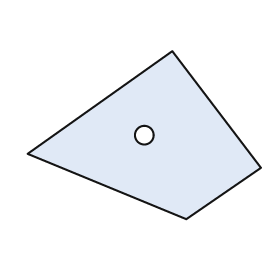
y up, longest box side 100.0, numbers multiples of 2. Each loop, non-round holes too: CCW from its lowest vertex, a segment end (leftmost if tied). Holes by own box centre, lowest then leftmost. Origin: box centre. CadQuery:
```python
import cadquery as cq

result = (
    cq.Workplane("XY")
    .moveTo(18.0, -36.0)
    .lineTo(50.0, -14.0)
    .lineTo(12.0, 36.0)
    .lineTo(-50.0, -8.0)
    .close()
    .moveTo(0.0, 0.0)
    .circle(4.0)
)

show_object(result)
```